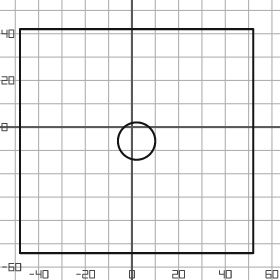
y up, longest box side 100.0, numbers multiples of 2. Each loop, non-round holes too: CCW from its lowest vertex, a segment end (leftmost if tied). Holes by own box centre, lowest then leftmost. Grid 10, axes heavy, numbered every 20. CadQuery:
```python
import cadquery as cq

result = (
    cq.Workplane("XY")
    .moveTo(-48.0, -54.0)
    .lineTo(52.0, -54.0)
    .lineTo(52.0, 42.0)
    .lineTo(-48.0, 42.0)
    .close()
    .moveTo(2.0, -6.0)
    .circle(8.0)
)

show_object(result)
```